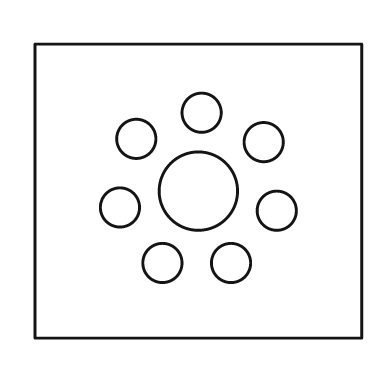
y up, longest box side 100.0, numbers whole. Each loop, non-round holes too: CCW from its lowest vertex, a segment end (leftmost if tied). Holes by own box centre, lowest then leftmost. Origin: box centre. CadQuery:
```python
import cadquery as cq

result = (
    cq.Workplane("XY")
    .moveTo(-50.0, -45.0)
    .lineTo(50.0, -45.0)
    .lineTo(50.0, 45.0)
    .lineTo(-50.0, 45.0)
    .close()
    .moveTo(-11.0, -22.0)
    .circle(6.0)
    .moveTo(10.0, -22.0)
    .circle(6.0)
    .moveTo(24.0, -6.0)
    .circle(6.0)
    .moveTo(-24.0, -5.0)
    .circle(6.0)
    .moveTo(0.0, 0.0)
    .circle(12.0)
    .moveTo(20.0, 15.0)
    .circle(6.0)
    .moveTo(-19.0, 16.0)
    .circle(6.0)
    .moveTo(1.0, 24.0)
    .circle(6.0)
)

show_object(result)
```